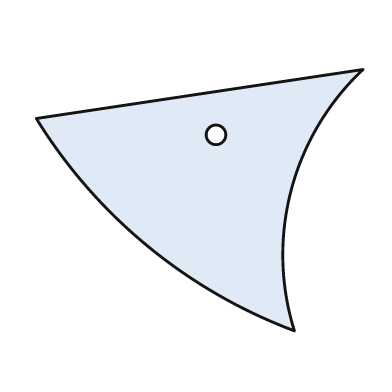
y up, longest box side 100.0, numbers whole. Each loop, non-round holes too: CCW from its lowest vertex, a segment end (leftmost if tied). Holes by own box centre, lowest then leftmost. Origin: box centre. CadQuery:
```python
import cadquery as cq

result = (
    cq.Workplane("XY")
    .moveTo(29.0, -40.0)
    .threePointArc((28.0, 3.0), (50.0, 40.0))
    .lineTo(-50.0, 25.0)
    .threePointArc((-16.0, -14.0), (29.0, -40.0))
    .close()
    .moveTo(5.0, 20.0)
    .circle(3.0)
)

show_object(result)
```